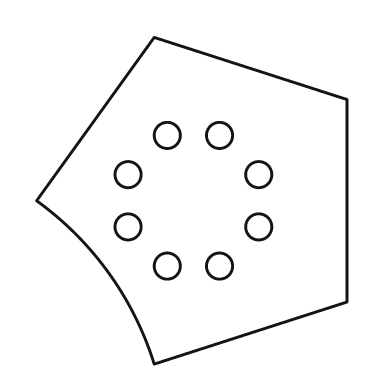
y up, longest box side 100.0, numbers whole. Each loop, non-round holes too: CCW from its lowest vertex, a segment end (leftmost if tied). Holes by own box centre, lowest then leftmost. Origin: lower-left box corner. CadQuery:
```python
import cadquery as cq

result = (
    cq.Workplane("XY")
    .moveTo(36.0, 0.0)
    .lineTo(95.0, 19.0)
    .lineTo(95.0, 81.0)
    .lineTo(36.0, 100.0)
    .lineTo(0.0, 50.0)
    .threePointArc((22.0, 28.0), (36.0, 0.0))
    .close()
    .moveTo(40.0, 30.0)
    .circle(4.0)
    .moveTo(56.0, 30.0)
    .circle(4.0)
    .moveTo(28.0, 42.0)
    .circle(4.0)
    .moveTo(68.0, 42.0)
    .circle(4.0)
    .moveTo(28.0, 58.0)
    .circle(4.0)
    .moveTo(68.0, 58.0)
    .circle(4.0)
    .moveTo(40.0, 70.0)
    .circle(4.0)
    .moveTo(56.0, 70.0)
    .circle(4.0)
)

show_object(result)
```